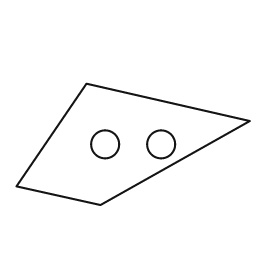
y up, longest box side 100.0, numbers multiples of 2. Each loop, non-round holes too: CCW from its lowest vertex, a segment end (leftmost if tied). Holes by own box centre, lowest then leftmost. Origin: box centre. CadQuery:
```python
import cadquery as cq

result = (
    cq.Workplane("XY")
    .moveTo(-14.0, -26.0)
    .lineTo(50.0, 10.0)
    .lineTo(-20.0, 26.0)
    .lineTo(-50.0, -18.0)
    .close()
    .moveTo(-12.0, 0.0)
    .circle(6.0)
    .moveTo(12.0, 0.0)
    .circle(6.0)
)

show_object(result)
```